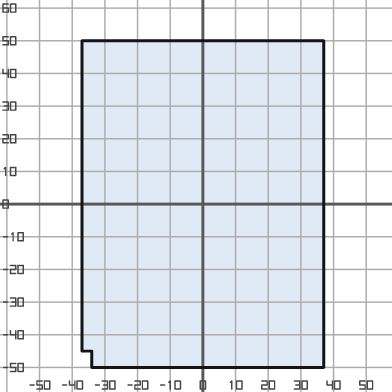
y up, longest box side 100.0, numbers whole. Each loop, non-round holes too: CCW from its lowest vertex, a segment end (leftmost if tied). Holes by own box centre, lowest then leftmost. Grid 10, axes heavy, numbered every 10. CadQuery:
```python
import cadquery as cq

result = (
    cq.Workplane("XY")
    .moveTo(-34.0, -50.0)
    .lineTo(37.0, -50.0)
    .lineTo(37.0, 50.0)
    .lineTo(-37.0, 50.0)
    .lineTo(-37.0, -45.0)
    .lineTo(-34.0, -45.0)
    .close()
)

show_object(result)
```